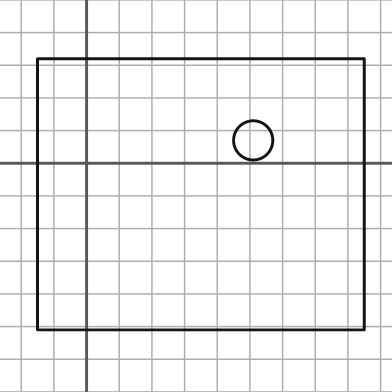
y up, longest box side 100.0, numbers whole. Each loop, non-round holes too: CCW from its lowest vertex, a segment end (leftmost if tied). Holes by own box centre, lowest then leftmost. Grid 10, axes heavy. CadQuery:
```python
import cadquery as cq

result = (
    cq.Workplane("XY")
    .moveTo(-15.0, -51.0)
    .lineTo(85.0, -51.0)
    .lineTo(85.0, 32.0)
    .lineTo(-15.0, 32.0)
    .close()
    .moveTo(51.0, 7.0)
    .circle(6.0)
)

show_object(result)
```